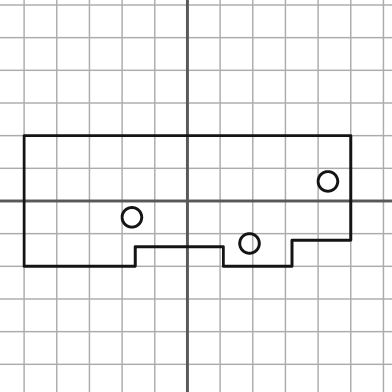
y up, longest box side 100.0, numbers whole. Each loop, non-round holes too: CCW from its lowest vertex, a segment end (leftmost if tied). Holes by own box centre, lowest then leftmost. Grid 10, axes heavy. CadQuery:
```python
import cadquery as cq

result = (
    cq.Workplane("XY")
    .moveTo(-50.0, -20.0)
    .lineTo(-16.0, -20.0)
    .lineTo(-16.0, -14.0)
    .lineTo(11.0, -14.0)
    .lineTo(11.0, -20.0)
    .lineTo(32.0, -20.0)
    .lineTo(32.0, -12.0)
    .lineTo(50.0, -12.0)
    .lineTo(50.0, 20.0)
    .lineTo(-50.0, 20.0)
    .close()
    .moveTo(19.0, -13.0)
    .circle(3.0)
    .moveTo(-17.0, -5.0)
    .circle(3.0)
    .moveTo(43.0, 6.0)
    .circle(3.0)
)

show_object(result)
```